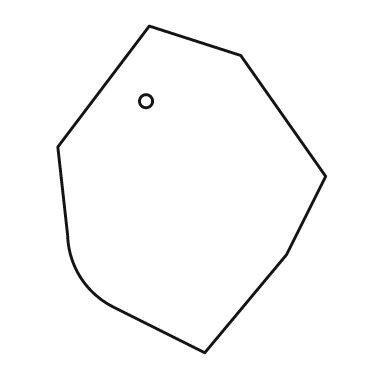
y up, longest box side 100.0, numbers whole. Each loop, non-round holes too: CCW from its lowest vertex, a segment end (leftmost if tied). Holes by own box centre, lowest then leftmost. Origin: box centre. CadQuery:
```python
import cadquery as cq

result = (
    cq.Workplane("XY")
    .moveTo(4.0, -50.0)
    .lineTo(29.0, -20.0)
    .lineTo(41.0, 4.0)
    .lineTo(15.0, 41.0)
    .lineTo(-13.0, 50.0)
    .lineTo(-41.0, 13.0)
    .lineTo(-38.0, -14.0)
    .threePointArc((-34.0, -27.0), (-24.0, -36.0))
    .close()
    .moveTo(-14.0, 27.0)
    .circle(2.0)
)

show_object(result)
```